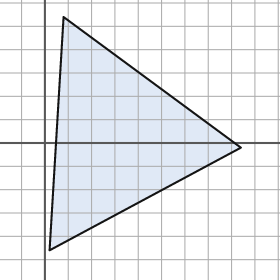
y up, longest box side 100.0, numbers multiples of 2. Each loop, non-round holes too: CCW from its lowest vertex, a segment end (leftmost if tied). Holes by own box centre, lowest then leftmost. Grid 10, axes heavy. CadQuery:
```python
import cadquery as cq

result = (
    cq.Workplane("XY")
    .moveTo(2.0, -46.0)
    .lineTo(84.0, -2.0)
    .lineTo(8.0, 54.0)
    .close()
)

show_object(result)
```